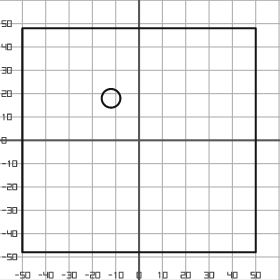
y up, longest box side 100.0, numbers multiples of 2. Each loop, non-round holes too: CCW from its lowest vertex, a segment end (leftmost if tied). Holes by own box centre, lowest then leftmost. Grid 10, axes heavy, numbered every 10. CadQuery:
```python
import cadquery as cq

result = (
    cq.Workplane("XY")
    .moveTo(-50.0, -48.0)
    .lineTo(50.0, -48.0)
    .lineTo(50.0, 48.0)
    .lineTo(-50.0, 48.0)
    .close()
    .moveTo(-12.0, 18.0)
    .circle(4.0)
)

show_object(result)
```